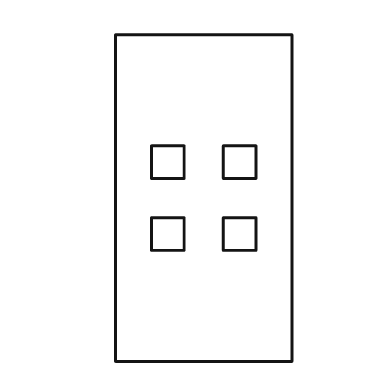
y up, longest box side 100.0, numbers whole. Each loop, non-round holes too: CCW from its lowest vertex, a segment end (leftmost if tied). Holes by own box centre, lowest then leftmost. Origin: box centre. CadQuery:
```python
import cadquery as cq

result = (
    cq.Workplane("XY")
    .moveTo(-27.0, -50.0)
    .lineTo(27.0, -50.0)
    .lineTo(27.0, 50.0)
    .lineTo(-27.0, 50.0)
    .close()
    .moveTo(-16.0, -16.0)
    .lineTo(-6.0, -16.0)
    .lineTo(-6.0, -6.0)
    .lineTo(-16.0, -6.0)
    .close()
    .moveTo(6.0, -16.0)
    .lineTo(16.0, -16.0)
    .lineTo(16.0, -6.0)
    .lineTo(6.0, -6.0)
    .close()
    .moveTo(-16.0, 6.0)
    .lineTo(-6.0, 6.0)
    .lineTo(-6.0, 16.0)
    .lineTo(-16.0, 16.0)
    .close()
    .moveTo(6.0, 6.0)
    .lineTo(16.0, 6.0)
    .lineTo(16.0, 16.0)
    .lineTo(6.0, 16.0)
    .close()
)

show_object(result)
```